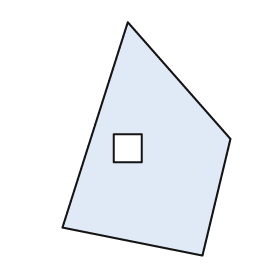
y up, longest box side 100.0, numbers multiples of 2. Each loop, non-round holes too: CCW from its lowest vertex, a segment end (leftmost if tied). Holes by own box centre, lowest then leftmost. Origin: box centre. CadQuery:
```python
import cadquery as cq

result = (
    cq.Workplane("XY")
    .moveTo(24.0, -50.0)
    .lineTo(36.0, 0.0)
    .lineTo(-8.0, 50.0)
    .lineTo(-36.0, -38.0)
    .close()
    .moveTo(-14.0, -10.0)
    .lineTo(-2.0, -10.0)
    .lineTo(-2.0, 2.0)
    .lineTo(-14.0, 2.0)
    .close()
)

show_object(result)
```